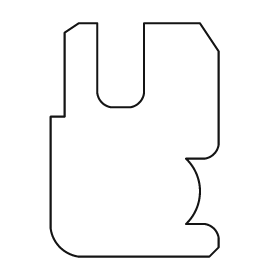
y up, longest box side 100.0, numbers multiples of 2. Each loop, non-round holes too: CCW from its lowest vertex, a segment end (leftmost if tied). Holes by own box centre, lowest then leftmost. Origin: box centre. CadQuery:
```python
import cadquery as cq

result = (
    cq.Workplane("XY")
    .moveTo(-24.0, -50.0)
    .lineTo(32.0, -50.0)
    .lineTo(36.0, -46.0)
    .lineTo(36.0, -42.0)
    .threePointArc((34.0, -38.0), (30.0, -36.0))
    .lineTo(22.0, -36.0)
    .threePointArc((28.0, -22.0), (22.0, -8.0))
    .lineTo(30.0, -8.0)
    .threePointArc((34.0, -6.0), (36.0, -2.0))
    .lineTo(36.0, 38.0)
    .lineTo(28.0, 50.0)
    .lineTo(4.0, 50.0)
    .lineTo(4.0, 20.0)
    .threePointArc((2.0, 16.0), (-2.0, 14.0))
    .lineTo(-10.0, 14.0)
    .threePointArc((-14.0, 16.0), (-16.0, 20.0))
    .lineTo(-16.0, 50.0)
    .lineTo(-24.0, 50.0)
    .lineTo(-30.0, 46.0)
    .lineTo(-30.0, 10.0)
    .lineTo(-36.0, 10.0)
    .lineTo(-36.0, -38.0)
    .threePointArc((-32.0, -46.0), (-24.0, -50.0))
    .close()
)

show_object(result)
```